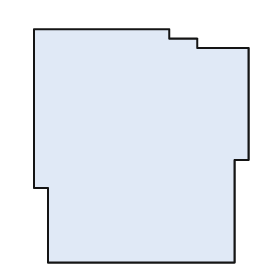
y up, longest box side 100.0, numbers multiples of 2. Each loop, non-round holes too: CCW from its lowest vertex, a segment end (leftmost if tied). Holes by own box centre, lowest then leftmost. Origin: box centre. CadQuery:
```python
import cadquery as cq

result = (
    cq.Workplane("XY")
    .moveTo(-40.0, -50.0)
    .lineTo(40.0, -50.0)
    .lineTo(40.0, -6.0)
    .lineTo(46.0, -6.0)
    .lineTo(46.0, 42.0)
    .lineTo(24.0, 42.0)
    .lineTo(24.0, 46.0)
    .lineTo(12.0, 46.0)
    .lineTo(12.0, 50.0)
    .lineTo(-46.0, 50.0)
    .lineTo(-46.0, -18.0)
    .lineTo(-40.0, -18.0)
    .close()
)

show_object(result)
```